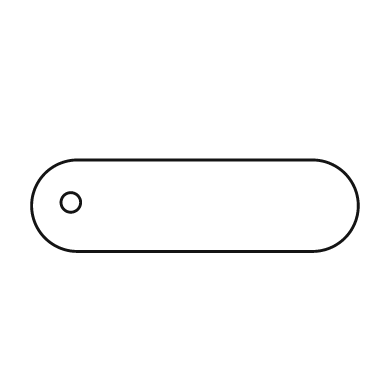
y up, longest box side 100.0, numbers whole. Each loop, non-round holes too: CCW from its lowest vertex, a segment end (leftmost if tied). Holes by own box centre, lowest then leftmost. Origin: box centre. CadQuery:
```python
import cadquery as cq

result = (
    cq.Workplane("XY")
    .moveTo(-36.0, -14.0)
    .lineTo(36.0, -14.0)
    .threePointArc((50.0, 0.0), (36.0, 14.0))
    .lineTo(-36.0, 14.0)
    .threePointArc((-50.0, 0.0), (-36.0, -14.0))
    .close()
    .moveTo(-38.0, 1.0)
    .circle(3.0)
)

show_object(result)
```